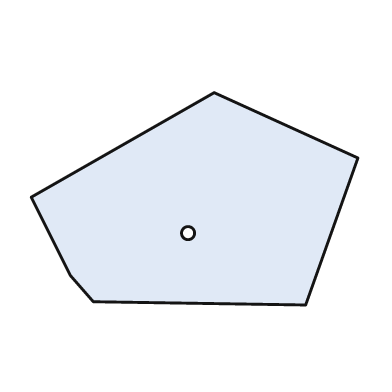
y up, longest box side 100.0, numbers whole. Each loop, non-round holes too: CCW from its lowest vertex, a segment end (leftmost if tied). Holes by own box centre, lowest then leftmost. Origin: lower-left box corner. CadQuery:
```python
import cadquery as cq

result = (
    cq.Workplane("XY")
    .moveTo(84.0, 0.0)
    .lineTo(100.0, 45.0)
    .lineTo(56.0, 65.0)
    .lineTo(0.0, 33.0)
    .lineTo(12.0, 9.0)
    .lineTo(19.0, 1.0)
    .close()
    .moveTo(48.0, 22.0)
    .circle(2.0)
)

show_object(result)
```